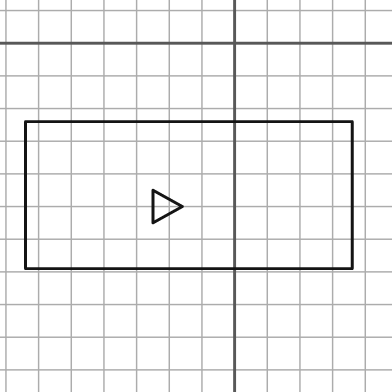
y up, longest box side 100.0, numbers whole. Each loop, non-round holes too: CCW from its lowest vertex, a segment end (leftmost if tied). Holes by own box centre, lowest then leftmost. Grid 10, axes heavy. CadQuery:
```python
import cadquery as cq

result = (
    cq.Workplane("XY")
    .moveTo(-64.0, -69.0)
    .lineTo(36.0, -69.0)
    .lineTo(36.0, -24.0)
    .lineTo(-64.0, -24.0)
    .close()
    .moveTo(-25.0, -55.0)
    .lineTo(-16.0, -50.0)
    .lineTo(-25.0, -45.0)
    .close()
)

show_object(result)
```